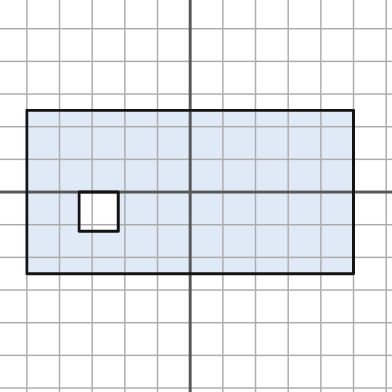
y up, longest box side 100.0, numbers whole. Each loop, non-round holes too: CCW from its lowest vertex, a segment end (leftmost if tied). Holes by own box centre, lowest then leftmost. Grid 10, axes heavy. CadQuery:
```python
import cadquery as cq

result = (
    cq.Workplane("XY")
    .moveTo(-50.0, -25.0)
    .lineTo(50.0, -25.0)
    .lineTo(50.0, 25.0)
    .lineTo(-50.0, 25.0)
    .close()
    .moveTo(-34.0, -12.0)
    .lineTo(-22.0, -12.0)
    .lineTo(-22.0, 0.0)
    .lineTo(-34.0, 0.0)
    .close()
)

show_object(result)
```